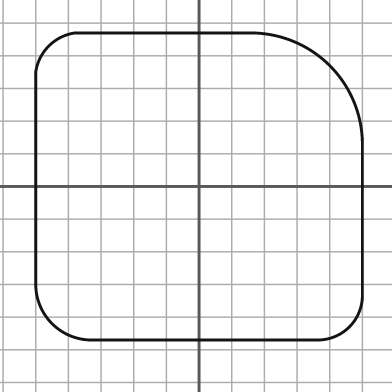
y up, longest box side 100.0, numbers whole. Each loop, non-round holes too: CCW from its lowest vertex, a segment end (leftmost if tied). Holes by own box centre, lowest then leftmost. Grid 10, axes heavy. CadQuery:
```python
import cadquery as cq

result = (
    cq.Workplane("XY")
    .moveTo(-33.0, -47.0)
    .lineTo(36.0, -47.0)
    .threePointArc((46.0, -43.0), (50.0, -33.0))
    .lineTo(50.0, 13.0)
    .threePointArc((40.0, 37.0), (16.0, 47.0))
    .lineTo(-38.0, 47.0)
    .threePointArc((-46.0, 43.0), (-50.0, 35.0))
    .lineTo(-50.0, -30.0)
    .threePointArc((-45.0, -42.0), (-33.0, -47.0))
    .close()
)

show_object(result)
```